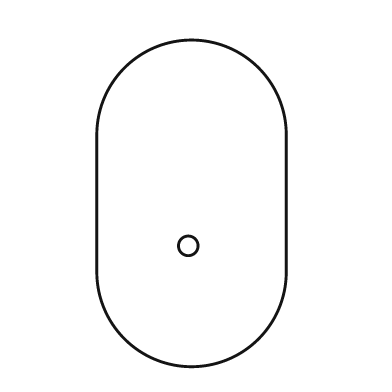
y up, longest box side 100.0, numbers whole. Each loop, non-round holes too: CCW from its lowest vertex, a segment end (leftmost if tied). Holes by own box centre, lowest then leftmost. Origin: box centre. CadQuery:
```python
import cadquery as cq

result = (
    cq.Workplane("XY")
    .moveTo(-29.0, -21.0)
    .threePointArc((0.0, -50.0), (29.0, -21.0))
    .lineTo(29.0, 21.0)
    .threePointArc((0.0, 50.0), (-29.0, 21.0))
    .close()
    .moveTo(-1.0, -13.0)
    .circle(3.0)
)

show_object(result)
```